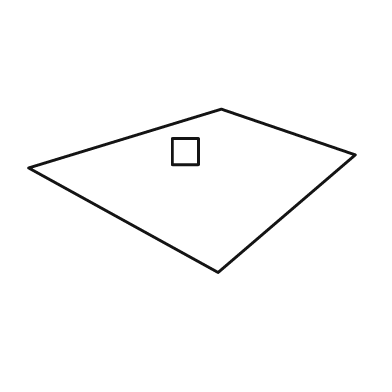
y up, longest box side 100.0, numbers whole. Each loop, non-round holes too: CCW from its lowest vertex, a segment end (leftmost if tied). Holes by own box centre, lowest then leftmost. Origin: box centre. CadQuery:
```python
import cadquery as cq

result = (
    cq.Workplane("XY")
    .moveTo(8.0, -25.0)
    .lineTo(50.0, 11.0)
    .lineTo(9.0, 25.0)
    .lineTo(-50.0, 7.0)
    .close()
    .moveTo(-6.0, 8.0)
    .lineTo(2.0, 8.0)
    .lineTo(2.0, 16.0)
    .lineTo(-6.0, 16.0)
    .close()
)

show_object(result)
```